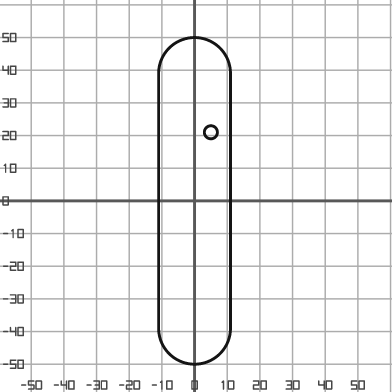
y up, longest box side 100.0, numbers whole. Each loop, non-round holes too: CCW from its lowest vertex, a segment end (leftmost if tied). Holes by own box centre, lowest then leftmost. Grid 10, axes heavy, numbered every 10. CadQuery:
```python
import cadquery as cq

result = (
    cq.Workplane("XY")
    .moveTo(-11.0, -39.0)
    .threePointArc((0.0, -50.0), (11.0, -39.0))
    .lineTo(11.0, 39.0)
    .threePointArc((0.0, 50.0), (-11.0, 39.0))
    .close()
    .moveTo(5.0, 21.0)
    .circle(2.0)
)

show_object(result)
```